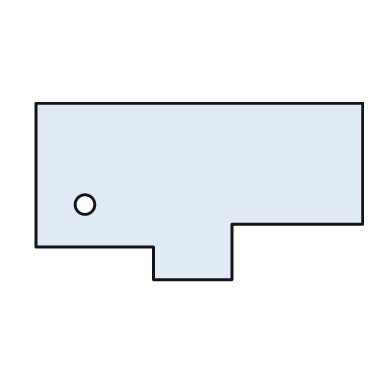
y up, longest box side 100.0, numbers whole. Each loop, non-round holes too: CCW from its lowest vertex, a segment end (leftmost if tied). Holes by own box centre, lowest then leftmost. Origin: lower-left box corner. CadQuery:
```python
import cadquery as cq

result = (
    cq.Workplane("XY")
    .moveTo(36.0, 0.0)
    .lineTo(60.0, 0.0)
    .lineTo(60.0, 17.0)
    .lineTo(100.0, 17.0)
    .lineTo(100.0, 54.0)
    .lineTo(0.0, 54.0)
    .lineTo(0.0, 10.0)
    .lineTo(36.0, 10.0)
    .close()
    .moveTo(15.0, 23.0)
    .circle(3.0)
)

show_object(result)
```